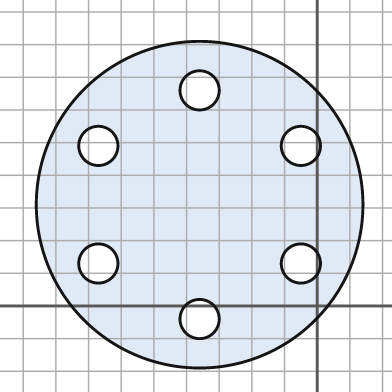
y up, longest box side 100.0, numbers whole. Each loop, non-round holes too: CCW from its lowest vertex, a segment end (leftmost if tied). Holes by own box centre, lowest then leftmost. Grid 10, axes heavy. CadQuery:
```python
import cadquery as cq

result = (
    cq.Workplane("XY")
    .moveTo(-36.0, 31.0)
    .circle(50.0)
    .moveTo(-36.0, -4.0)
    .circle(6.0)
    .moveTo(-67.0, 13.0)
    .circle(6.0)
    .moveTo(-5.0, 13.0)
    .circle(6.0)
    .moveTo(-67.0, 49.0)
    .circle(6.0)
    .moveTo(-5.0, 49.0)
    .circle(6.0)
    .moveTo(-36.0, 66.0)
    .circle(6.0)
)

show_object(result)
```